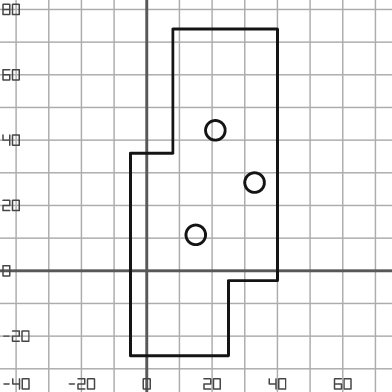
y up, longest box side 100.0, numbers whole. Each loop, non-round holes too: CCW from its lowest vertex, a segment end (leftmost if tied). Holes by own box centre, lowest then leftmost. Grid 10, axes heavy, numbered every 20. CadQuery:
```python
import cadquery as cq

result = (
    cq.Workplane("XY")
    .moveTo(-5.0, -26.0)
    .lineTo(25.0, -26.0)
    .lineTo(25.0, -3.0)
    .lineTo(40.0, -3.0)
    .lineTo(40.0, 74.0)
    .lineTo(8.0, 74.0)
    .lineTo(8.0, 36.0)
    .lineTo(-5.0, 36.0)
    .close()
    .moveTo(15.0, 11.0)
    .circle(3.0)
    .moveTo(33.0, 27.0)
    .circle(3.0)
    .moveTo(21.0, 43.0)
    .circle(3.0)
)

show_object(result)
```